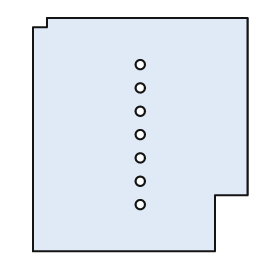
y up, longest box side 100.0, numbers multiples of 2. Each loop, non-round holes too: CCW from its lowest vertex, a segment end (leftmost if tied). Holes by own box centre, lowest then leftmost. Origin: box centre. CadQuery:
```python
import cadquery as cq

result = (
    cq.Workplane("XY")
    .moveTo(-46.0, -50.0)
    .lineTo(32.0, -50.0)
    .lineTo(32.0, -26.0)
    .lineTo(46.0, -26.0)
    .lineTo(46.0, 50.0)
    .lineTo(-40.0, 50.0)
    .lineTo(-40.0, 46.0)
    .lineTo(-46.0, 46.0)
    .close()
    .moveTo(0.0, -30.0)
    .circle(2.0)
    .moveTo(0.0, -20.0)
    .circle(2.0)
    .moveTo(0.0, -10.0)
    .circle(2.0)
    .moveTo(0.0, 0.0)
    .circle(2.0)
    .moveTo(0.0, 10.0)
    .circle(2.0)
    .moveTo(0.0, 20.0)
    .circle(2.0)
    .moveTo(0.0, 30.0)
    .circle(2.0)
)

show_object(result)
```